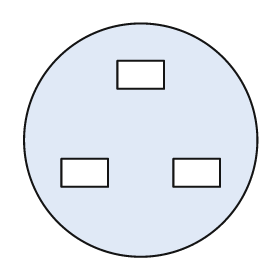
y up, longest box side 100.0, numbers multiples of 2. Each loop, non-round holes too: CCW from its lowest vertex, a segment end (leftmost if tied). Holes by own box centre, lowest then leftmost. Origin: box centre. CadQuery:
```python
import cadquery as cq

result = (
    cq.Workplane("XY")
    .moveTo(0.0, 0.0)
    .circle(50.0)
    .moveTo(-34.0, -20.0)
    .lineTo(-14.0, -20.0)
    .lineTo(-14.0, -8.0)
    .lineTo(-34.0, -8.0)
    .close()
    .moveTo(14.0, -20.0)
    .lineTo(34.0, -20.0)
    .lineTo(34.0, -8.0)
    .lineTo(14.0, -8.0)
    .close()
    .moveTo(-10.0, 22.0)
    .lineTo(10.0, 22.0)
    .lineTo(10.0, 34.0)
    .lineTo(-10.0, 34.0)
    .close()
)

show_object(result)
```